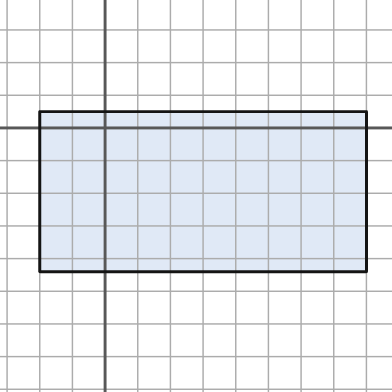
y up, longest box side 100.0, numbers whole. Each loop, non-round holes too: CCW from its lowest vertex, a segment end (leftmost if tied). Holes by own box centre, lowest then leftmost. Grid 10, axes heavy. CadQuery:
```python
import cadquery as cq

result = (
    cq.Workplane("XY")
    .moveTo(-20.0, -44.0)
    .lineTo(80.0, -44.0)
    .lineTo(80.0, 5.0)
    .lineTo(-20.0, 5.0)
    .close()
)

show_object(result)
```